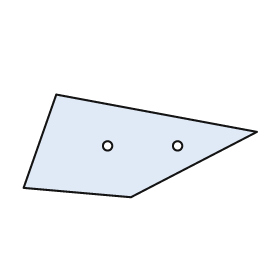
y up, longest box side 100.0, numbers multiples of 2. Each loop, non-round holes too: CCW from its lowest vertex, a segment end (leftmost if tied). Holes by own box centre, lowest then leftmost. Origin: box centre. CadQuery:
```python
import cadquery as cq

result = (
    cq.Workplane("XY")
    .moveTo(-4.0, -22.0)
    .lineTo(50.0, 6.0)
    .lineTo(-36.0, 22.0)
    .lineTo(-50.0, -18.0)
    .close()
    .moveTo(-14.0, 0.0)
    .circle(2.0)
    .moveTo(16.0, 0.0)
    .circle(2.0)
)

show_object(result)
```